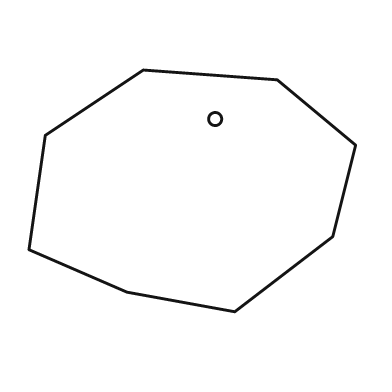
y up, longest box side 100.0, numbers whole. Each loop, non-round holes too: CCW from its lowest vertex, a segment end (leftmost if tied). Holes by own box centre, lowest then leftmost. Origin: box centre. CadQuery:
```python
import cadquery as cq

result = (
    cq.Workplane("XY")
    .moveTo(13.0, -37.0)
    .lineTo(43.0, -14.0)
    .lineTo(50.0, 14.0)
    .lineTo(26.0, 34.0)
    .lineTo(-15.0, 37.0)
    .lineTo(-45.0, 17.0)
    .lineTo(-50.0, -18.0)
    .lineTo(-20.0, -31.0)
    .close()
    .moveTo(7.0, 22.0)
    .circle(2.0)
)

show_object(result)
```